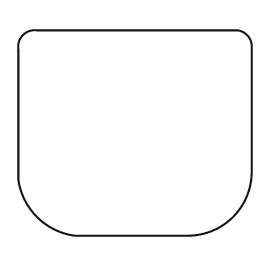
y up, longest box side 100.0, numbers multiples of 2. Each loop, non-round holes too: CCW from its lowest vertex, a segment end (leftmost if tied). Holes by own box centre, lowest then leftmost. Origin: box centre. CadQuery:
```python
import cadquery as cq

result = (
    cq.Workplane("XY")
    .moveTo(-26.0, -44.0)
    .lineTo(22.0, -44.0)
    .threePointArc((42.0, -36.0), (50.0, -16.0))
    .lineTo(50.0, 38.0)
    .threePointArc((48.0, 42.0), (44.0, 44.0))
    .lineTo(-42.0, 44.0)
    .threePointArc((-48.0, 42.0), (-50.0, 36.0))
    .lineTo(-50.0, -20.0)
    .threePointArc((-42.0, -36.0), (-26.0, -44.0))
    .close()
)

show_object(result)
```